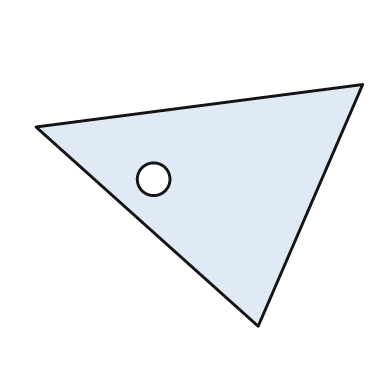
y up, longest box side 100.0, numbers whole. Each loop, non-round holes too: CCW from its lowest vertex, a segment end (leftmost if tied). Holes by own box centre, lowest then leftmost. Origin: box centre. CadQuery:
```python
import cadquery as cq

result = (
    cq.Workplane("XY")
    .moveTo(18.0, -37.0)
    .lineTo(50.0, 37.0)
    .lineTo(-50.0, 24.0)
    .close()
    .moveTo(-14.0, 8.0)
    .circle(5.0)
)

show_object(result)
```